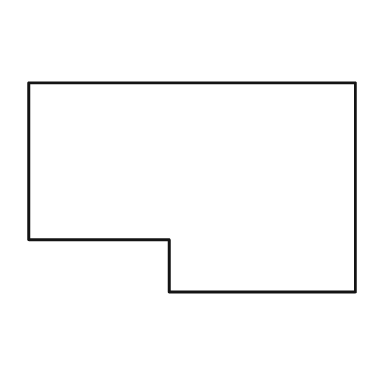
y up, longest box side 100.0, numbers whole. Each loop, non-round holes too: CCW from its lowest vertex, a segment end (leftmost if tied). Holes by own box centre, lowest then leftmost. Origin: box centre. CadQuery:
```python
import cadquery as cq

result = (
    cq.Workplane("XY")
    .moveTo(-7.0, -32.0)
    .lineTo(50.0, -32.0)
    .lineTo(50.0, 32.0)
    .lineTo(-50.0, 32.0)
    .lineTo(-50.0, -16.0)
    .lineTo(-7.0, -16.0)
    .close()
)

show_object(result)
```